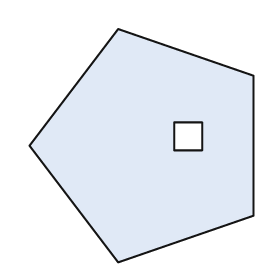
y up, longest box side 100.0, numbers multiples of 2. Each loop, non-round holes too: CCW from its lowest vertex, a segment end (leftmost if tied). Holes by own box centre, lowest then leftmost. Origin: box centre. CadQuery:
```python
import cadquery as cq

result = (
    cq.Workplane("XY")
    .moveTo(-10.0, -50.0)
    .lineTo(48.0, -30.0)
    .lineTo(48.0, 30.0)
    .lineTo(-10.0, 50.0)
    .lineTo(-48.0, 0.0)
    .close()
    .moveTo(14.0, -2.0)
    .lineTo(26.0, -2.0)
    .lineTo(26.0, 10.0)
    .lineTo(14.0, 10.0)
    .close()
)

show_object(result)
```